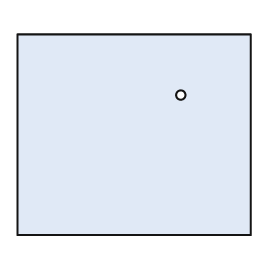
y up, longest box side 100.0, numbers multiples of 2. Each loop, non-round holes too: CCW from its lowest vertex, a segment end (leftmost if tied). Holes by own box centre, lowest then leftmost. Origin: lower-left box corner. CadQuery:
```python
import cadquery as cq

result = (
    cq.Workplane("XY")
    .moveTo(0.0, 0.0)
    .lineTo(100.0, 0.0)
    .lineTo(100.0, 86.0)
    .lineTo(0.0, 86.0)
    .close()
    .moveTo(70.0, 60.0)
    .circle(2.0)
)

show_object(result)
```